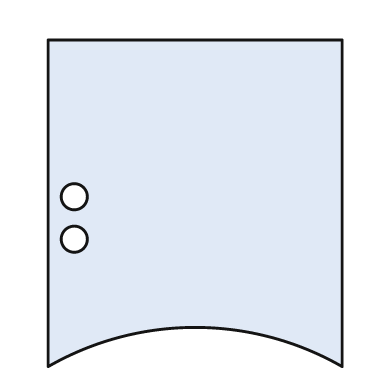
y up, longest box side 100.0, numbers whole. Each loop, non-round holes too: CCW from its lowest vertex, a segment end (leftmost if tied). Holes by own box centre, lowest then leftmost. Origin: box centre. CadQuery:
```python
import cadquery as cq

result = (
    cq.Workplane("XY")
    .moveTo(-45.0, -50.0)
    .threePointArc((0.0, -38.0), (45.0, -50.0))
    .lineTo(45.0, 50.0)
    .lineTo(-45.0, 50.0)
    .close()
    .moveTo(-37.0, -11.0)
    .circle(4.0)
    .moveTo(-37.0, 2.0)
    .circle(4.0)
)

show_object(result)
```